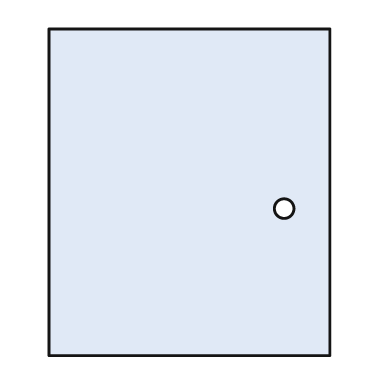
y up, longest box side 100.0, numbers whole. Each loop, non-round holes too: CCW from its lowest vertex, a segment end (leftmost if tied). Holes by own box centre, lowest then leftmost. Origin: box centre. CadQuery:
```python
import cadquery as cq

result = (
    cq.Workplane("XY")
    .moveTo(-43.0, -50.0)
    .lineTo(43.0, -50.0)
    .lineTo(43.0, 50.0)
    .lineTo(-43.0, 50.0)
    .close()
    .moveTo(29.0, -5.0)
    .circle(3.0)
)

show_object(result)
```